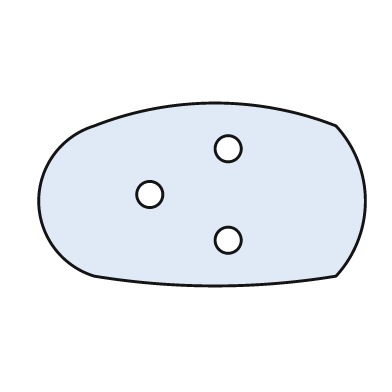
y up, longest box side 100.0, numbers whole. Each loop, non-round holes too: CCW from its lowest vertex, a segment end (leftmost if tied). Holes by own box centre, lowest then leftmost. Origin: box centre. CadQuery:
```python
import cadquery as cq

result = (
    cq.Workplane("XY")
    .moveTo(-33.0, -25.0)
    .threePointArc((4.0, -28.0), (41.0, -25.0))
    .threePointArc((50.0, -2.0), (41.0, 21.0))
    .threePointArc((4.0, 28.0), (-33.0, 21.0))
    .threePointArc((-50.0, -2.0), (-33.0, -25.0))
    .close()
    .moveTo(8.0, -14.0)
    .circle(4.0)
    .moveTo(-16.0, 0.0)
    .circle(4.0)
    .moveTo(8.0, 14.0)
    .circle(4.0)
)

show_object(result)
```